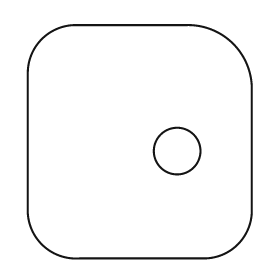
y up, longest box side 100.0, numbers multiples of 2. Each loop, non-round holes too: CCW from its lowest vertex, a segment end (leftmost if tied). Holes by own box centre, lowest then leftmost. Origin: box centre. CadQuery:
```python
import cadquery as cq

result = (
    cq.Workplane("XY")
    .moveTo(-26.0, -50.0)
    .lineTo(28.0, -50.0)
    .threePointArc((42.0, -44.0), (48.0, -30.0))
    .lineTo(48.0, 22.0)
    .threePointArc((40.0, 42.0), (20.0, 50.0))
    .lineTo(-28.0, 50.0)
    .threePointArc((-42.0, 44.0), (-48.0, 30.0))
    .lineTo(-48.0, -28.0)
    .threePointArc((-42.0, -44.0), (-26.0, -50.0))
    .close()
    .moveTo(16.0, -4.0)
    .circle(10.0)
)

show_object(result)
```